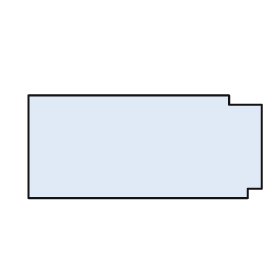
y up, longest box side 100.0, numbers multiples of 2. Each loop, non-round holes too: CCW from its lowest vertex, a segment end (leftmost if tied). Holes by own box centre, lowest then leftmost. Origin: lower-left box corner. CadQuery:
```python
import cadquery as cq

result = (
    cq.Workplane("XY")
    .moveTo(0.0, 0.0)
    .lineTo(94.0, 0.0)
    .lineTo(94.0, 4.0)
    .lineTo(100.0, 4.0)
    .lineTo(100.0, 40.0)
    .lineTo(86.0, 40.0)
    .lineTo(86.0, 44.0)
    .lineTo(0.0, 44.0)
    .close()
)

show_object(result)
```